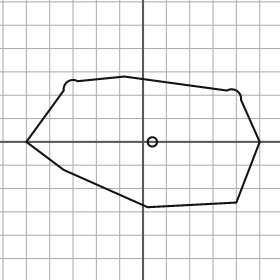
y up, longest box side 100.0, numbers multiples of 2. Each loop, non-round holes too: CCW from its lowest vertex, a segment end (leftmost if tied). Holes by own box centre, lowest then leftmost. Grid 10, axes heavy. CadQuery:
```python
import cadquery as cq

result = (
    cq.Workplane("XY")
    .moveTo(2.0, -28.0)
    .lineTo(40.0, -26.0)
    .lineTo(50.0, 0.0)
    .lineTo(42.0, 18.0)
    .threePointArc((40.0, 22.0), (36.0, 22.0))
    .lineTo(-8.0, 28.0)
    .lineTo(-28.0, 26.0)
    .threePointArc((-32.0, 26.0), (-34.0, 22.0))
    .lineTo(-50.0, 0.0)
    .lineTo(-34.0, -12.0)
    .close()
    .moveTo(4.0, 0.0)
    .circle(2.0)
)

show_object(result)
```